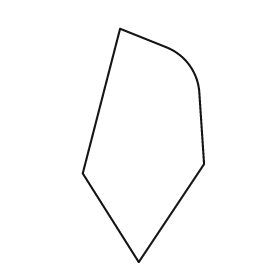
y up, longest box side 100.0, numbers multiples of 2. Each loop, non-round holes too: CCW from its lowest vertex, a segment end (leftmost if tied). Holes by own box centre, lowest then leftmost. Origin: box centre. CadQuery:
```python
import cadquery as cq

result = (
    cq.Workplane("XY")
    .moveTo(-2.0, -50.0)
    .lineTo(26.0, -8.0)
    .lineTo(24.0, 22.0)
    .threePointArc((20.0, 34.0), (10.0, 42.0))
    .lineTo(-10.0, 50.0)
    .lineTo(-26.0, -12.0)
    .close()
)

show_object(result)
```